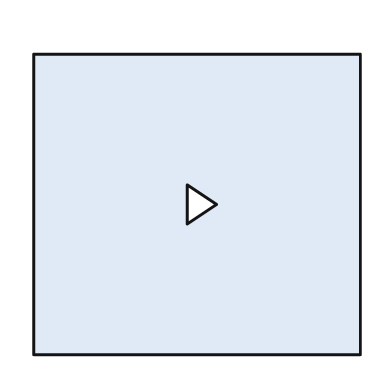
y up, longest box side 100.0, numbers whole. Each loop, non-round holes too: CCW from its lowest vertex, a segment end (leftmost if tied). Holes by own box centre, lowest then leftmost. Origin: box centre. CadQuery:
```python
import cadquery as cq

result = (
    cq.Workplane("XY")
    .moveTo(-50.0, -46.0)
    .lineTo(50.0, -46.0)
    .lineTo(50.0, 46.0)
    .lineTo(-50.0, 46.0)
    .close()
    .moveTo(-3.0, -6.0)
    .lineTo(6.0, 0.0)
    .lineTo(-3.0, 6.0)
    .close()
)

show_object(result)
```